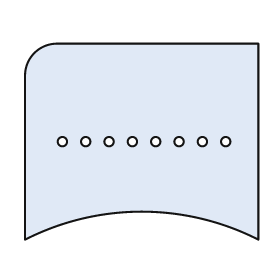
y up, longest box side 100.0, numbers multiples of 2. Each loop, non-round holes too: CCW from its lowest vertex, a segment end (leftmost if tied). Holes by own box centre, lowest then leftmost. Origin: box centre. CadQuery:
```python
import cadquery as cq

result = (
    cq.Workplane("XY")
    .moveTo(-50.0, -42.0)
    .threePointArc((0.0, -30.0), (50.0, -42.0))
    .lineTo(50.0, 42.0)
    .lineTo(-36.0, 42.0)
    .threePointArc((-46.0, 38.0), (-50.0, 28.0))
    .close()
    .moveTo(-34.0, 0.0)
    .circle(2.0)
    .moveTo(-24.0, 0.0)
    .circle(2.0)
    .moveTo(-14.0, 0.0)
    .circle(2.0)
    .moveTo(-4.0, 0.0)
    .circle(2.0)
    .moveTo(6.0, 0.0)
    .circle(2.0)
    .moveTo(16.0, 0.0)
    .circle(2.0)
    .moveTo(26.0, 0.0)
    .circle(2.0)
    .moveTo(36.0, 0.0)
    .circle(2.0)
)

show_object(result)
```